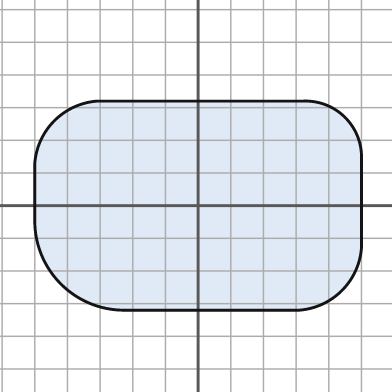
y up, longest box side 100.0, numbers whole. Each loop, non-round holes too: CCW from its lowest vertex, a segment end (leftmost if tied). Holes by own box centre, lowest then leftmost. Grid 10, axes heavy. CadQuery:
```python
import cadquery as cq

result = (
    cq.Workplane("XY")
    .moveTo(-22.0, -32.0)
    .lineTo(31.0, -32.0)
    .threePointArc((44.0, -26.0), (50.0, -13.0))
    .lineTo(50.0, 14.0)
    .threePointArc((45.0, 27.0), (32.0, 32.0))
    .lineTo(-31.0, 32.0)
    .threePointArc((-44.0, 26.0), (-50.0, 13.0))
    .lineTo(-50.0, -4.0)
    .threePointArc((-42.0, -24.0), (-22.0, -32.0))
    .close()
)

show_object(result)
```